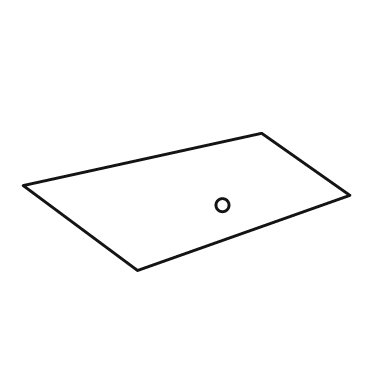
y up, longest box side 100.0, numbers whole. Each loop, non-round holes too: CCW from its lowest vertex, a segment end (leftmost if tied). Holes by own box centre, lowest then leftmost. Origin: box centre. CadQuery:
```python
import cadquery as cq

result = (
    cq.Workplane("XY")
    .moveTo(-15.0, -21.0)
    .lineTo(50.0, 2.0)
    .lineTo(23.0, 21.0)
    .lineTo(-50.0, 5.0)
    .close()
    .moveTo(11.0, -1.0)
    .circle(2.0)
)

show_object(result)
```